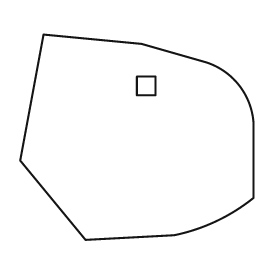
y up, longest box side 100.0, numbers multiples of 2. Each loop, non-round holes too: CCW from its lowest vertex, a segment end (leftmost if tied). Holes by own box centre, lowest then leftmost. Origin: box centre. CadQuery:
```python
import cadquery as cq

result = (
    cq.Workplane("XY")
    .moveTo(-22.0, -44.0)
    .lineTo(16.0, -42.0)
    .threePointArc((34.0, -36.0), (50.0, -26.0))
    .lineTo(50.0, 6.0)
    .threePointArc((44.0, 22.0), (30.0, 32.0))
    .lineTo(2.0, 40.0)
    .lineTo(-40.0, 44.0)
    .lineTo(-50.0, -10.0)
    .close()
    .moveTo(0.0, 18.0)
    .lineTo(8.0, 18.0)
    .lineTo(8.0, 26.0)
    .lineTo(0.0, 26.0)
    .close()
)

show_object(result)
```